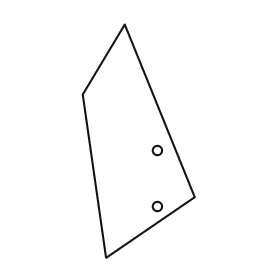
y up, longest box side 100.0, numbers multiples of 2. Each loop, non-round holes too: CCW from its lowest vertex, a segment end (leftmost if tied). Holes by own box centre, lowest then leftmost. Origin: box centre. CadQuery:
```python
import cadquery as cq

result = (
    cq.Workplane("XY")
    .moveTo(-14.0, -50.0)
    .lineTo(24.0, -24.0)
    .lineTo(-6.0, 50.0)
    .lineTo(-24.0, 20.0)
    .close()
    .moveTo(8.0, -28.0)
    .circle(2.0)
    .moveTo(8.0, -4.0)
    .circle(2.0)
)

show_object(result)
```